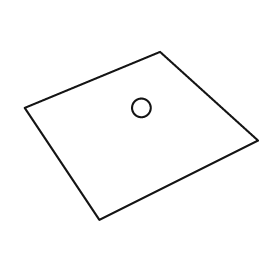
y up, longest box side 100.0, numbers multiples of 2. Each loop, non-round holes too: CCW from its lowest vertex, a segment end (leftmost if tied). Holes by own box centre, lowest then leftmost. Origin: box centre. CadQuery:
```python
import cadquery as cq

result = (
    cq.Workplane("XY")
    .moveTo(-18.0, -36.0)
    .lineTo(50.0, -2.0)
    .lineTo(8.0, 36.0)
    .lineTo(-50.0, 12.0)
    .close()
    .moveTo(0.0, 12.0)
    .circle(4.0)
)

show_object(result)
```